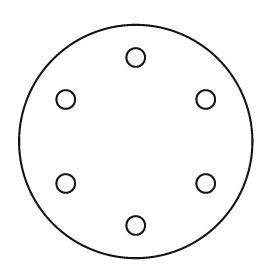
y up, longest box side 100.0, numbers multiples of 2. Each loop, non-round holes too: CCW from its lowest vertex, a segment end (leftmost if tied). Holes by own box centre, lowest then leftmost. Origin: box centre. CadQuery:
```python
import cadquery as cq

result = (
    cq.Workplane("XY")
    .moveTo(0.0, 0.0)
    .circle(50.0)
    .moveTo(0.0, -36.0)
    .circle(4.0)
    .moveTo(-30.0, -18.0)
    .circle(4.0)
    .moveTo(30.0, -18.0)
    .circle(4.0)
    .moveTo(-30.0, 18.0)
    .circle(4.0)
    .moveTo(30.0, 18.0)
    .circle(4.0)
    .moveTo(0.0, 36.0)
    .circle(4.0)
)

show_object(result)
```